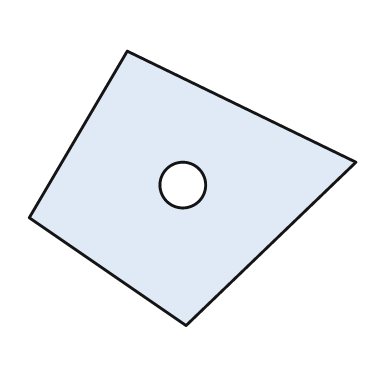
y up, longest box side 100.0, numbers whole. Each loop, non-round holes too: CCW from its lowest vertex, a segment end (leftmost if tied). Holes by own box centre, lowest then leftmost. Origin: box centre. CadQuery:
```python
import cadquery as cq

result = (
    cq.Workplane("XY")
    .moveTo(-2.0, -42.0)
    .lineTo(50.0, 8.0)
    .lineTo(-20.0, 42.0)
    .lineTo(-50.0, -9.0)
    .close()
    .moveTo(-3.0, 1.0)
    .circle(7.0)
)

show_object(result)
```